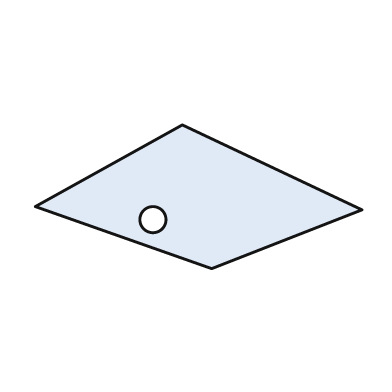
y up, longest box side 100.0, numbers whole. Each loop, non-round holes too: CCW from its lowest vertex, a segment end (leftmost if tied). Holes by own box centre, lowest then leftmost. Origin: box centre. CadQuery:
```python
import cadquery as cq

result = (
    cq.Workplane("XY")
    .moveTo(4.0, -22.0)
    .lineTo(50.0, -4.0)
    .lineTo(-5.0, 22.0)
    .lineTo(-50.0, -3.0)
    .close()
    .moveTo(-14.0, -7.0)
    .circle(4.0)
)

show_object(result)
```